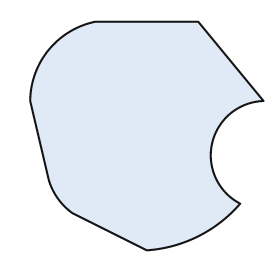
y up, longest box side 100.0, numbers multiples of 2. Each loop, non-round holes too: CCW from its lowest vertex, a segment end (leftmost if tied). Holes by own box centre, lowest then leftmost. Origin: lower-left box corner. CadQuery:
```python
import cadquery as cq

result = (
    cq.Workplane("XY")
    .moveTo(50.0, 0.0)
    .threePointArc((72.0, 6.0), (90.0, 20.0))
    .threePointArc((78.0, 46.0), (100.0, 64.0))
    .lineTo(72.0, 98.0)
    .lineTo(28.0, 98.0)
    .threePointArc((8.0, 86.0), (0.0, 64.0))
    .lineTo(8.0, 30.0)
    .threePointArc((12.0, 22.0), (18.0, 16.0))
    .close()
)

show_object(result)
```